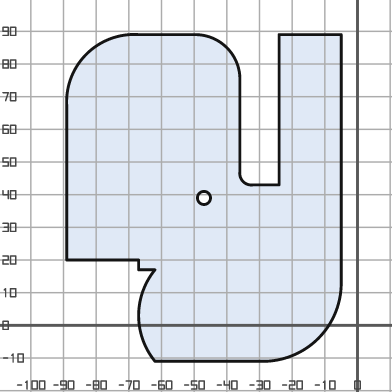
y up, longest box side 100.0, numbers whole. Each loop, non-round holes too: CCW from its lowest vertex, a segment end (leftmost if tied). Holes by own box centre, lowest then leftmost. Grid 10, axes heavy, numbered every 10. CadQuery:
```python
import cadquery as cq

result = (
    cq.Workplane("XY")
    .moveTo(-62.0, -11.0)
    .lineTo(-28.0, -11.0)
    .threePointArc((-12.0, -4.0), (-5.0, 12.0))
    .lineTo(-5.0, 89.0)
    .lineTo(-24.0, 89.0)
    .lineTo(-24.0, 43.0)
    .lineTo(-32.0, 43.0)
    .threePointArc((-35.0, 44.0), (-36.0, 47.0))
    .lineTo(-36.0, 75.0)
    .threePointArc((-40.0, 85.0), (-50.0, 89.0))
    .lineTo(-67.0, 89.0)
    .threePointArc((-83.0, 83.0), (-89.0, 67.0))
    .lineTo(-89.0, 20.0)
    .lineTo(-67.0, 20.0)
    .lineTo(-67.0, 17.0)
    .lineTo(-62.0, 17.0)
    .threePointArc((-67.0, 3.0), (-62.0, -11.0))
    .close()
    .moveTo(-47.0, 39.0)
    .circle(2.0)
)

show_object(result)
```